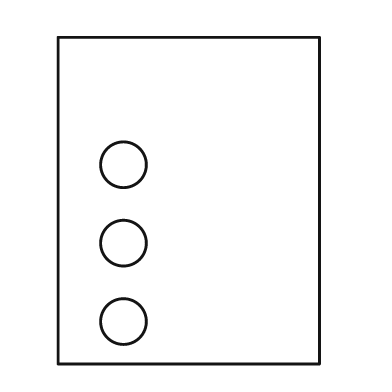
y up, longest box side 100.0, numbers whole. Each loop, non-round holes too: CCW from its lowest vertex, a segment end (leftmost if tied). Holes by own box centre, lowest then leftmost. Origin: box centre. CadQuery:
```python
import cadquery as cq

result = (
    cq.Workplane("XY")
    .moveTo(-40.0, -50.0)
    .lineTo(40.0, -50.0)
    .lineTo(40.0, 50.0)
    .lineTo(-40.0, 50.0)
    .close()
    .moveTo(-20.0, -37.0)
    .circle(7.0)
    .moveTo(-20.0, -13.0)
    .circle(7.0)
    .moveTo(-20.0, 11.0)
    .circle(7.0)
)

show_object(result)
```